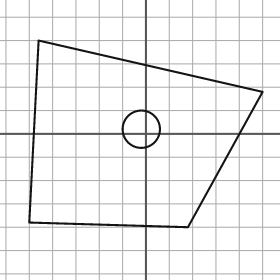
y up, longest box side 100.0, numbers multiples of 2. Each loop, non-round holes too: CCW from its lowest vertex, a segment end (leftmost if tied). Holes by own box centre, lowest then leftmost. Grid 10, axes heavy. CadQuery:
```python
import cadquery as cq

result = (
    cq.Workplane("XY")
    .moveTo(18.0, -40.0)
    .lineTo(50.0, 18.0)
    .lineTo(-46.0, 40.0)
    .lineTo(-50.0, -38.0)
    .close()
    .moveTo(-2.0, 2.0)
    .circle(8.0)
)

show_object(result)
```